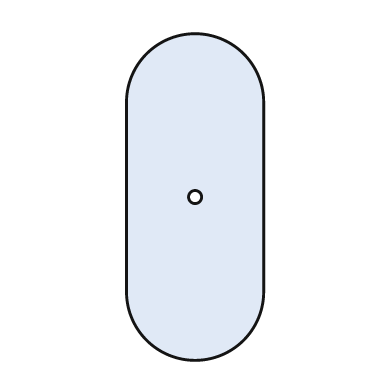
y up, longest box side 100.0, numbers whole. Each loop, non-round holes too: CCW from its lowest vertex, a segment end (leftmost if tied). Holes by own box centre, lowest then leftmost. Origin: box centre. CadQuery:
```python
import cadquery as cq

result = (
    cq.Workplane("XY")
    .moveTo(-21.0, -29.0)
    .threePointArc((0.0, -50.0), (21.0, -29.0))
    .lineTo(21.0, 29.0)
    .threePointArc((0.0, 50.0), (-21.0, 29.0))
    .close()
    .moveTo(0.0, 0.0)
    .circle(2.0)
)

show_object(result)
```